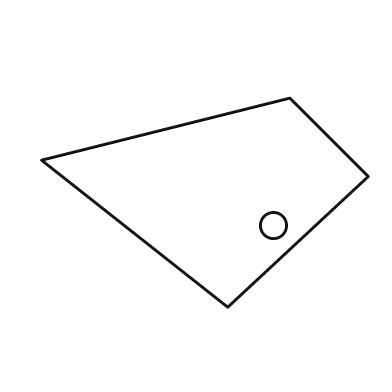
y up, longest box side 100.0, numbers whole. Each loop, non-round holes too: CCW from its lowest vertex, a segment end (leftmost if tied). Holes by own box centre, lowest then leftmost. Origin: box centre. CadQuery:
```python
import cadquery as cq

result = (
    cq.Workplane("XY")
    .moveTo(7.0, -32.0)
    .lineTo(50.0, 8.0)
    .lineTo(26.0, 32.0)
    .lineTo(-50.0, 13.0)
    .close()
    .moveTo(21.0, -7.0)
    .circle(4.0)
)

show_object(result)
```